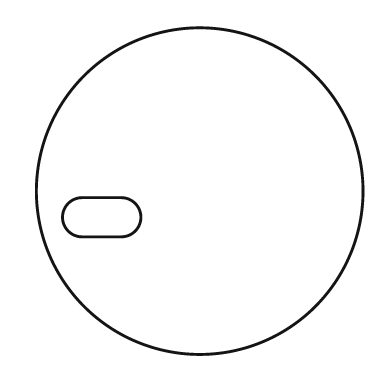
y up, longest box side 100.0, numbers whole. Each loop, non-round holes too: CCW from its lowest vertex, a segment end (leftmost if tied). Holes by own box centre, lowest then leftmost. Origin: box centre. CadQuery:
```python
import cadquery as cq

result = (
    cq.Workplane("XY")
    .moveTo(0.0, 0.0)
    .circle(50.0)
    .moveTo(-36.0, -14.0)
    .lineTo(-24.0, -14.0)
    .threePointArc((-18.0, -8.0), (-24.0, -2.0))
    .lineTo(-36.0, -2.0)
    .threePointArc((-42.0, -8.0), (-36.0, -14.0))
    .close()
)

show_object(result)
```